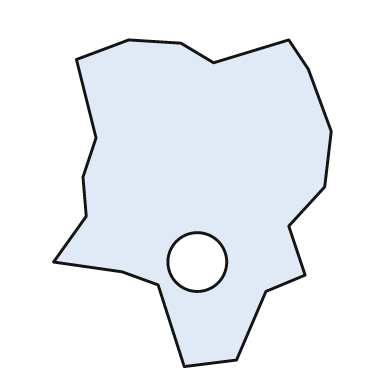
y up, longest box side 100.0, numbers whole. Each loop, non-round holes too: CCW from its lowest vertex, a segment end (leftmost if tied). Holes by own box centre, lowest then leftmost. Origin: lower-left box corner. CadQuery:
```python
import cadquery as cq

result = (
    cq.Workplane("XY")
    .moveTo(40.0, 0.0)
    .lineTo(56.0, 2.0)
    .lineTo(65.0, 23.0)
    .lineTo(77.0, 28.0)
    .lineTo(72.0, 43.0)
    .lineTo(83.0, 55.0)
    .lineTo(85.0, 72.0)
    .lineTo(78.0, 91.0)
    .lineTo(72.0, 100.0)
    .lineTo(49.0, 93.0)
    .lineTo(39.0, 99.0)
    .lineTo(23.0, 100.0)
    .lineTo(7.0, 94.0)
    .lineTo(13.0, 70.0)
    .lineTo(9.0, 58.0)
    .lineTo(10.0, 46.0)
    .lineTo(0.0, 32.0)
    .lineTo(21.0, 29.0)
    .lineTo(32.0, 25.0)
    .close()
    .moveTo(44.0, 32.0)
    .circle(9.0)
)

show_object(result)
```